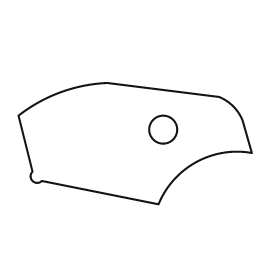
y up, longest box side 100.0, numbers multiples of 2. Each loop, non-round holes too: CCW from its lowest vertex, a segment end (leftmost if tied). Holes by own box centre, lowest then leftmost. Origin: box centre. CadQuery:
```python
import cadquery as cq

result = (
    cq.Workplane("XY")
    .moveTo(10.0, -26.0)
    .threePointArc((26.0, -8.0), (50.0, -4.0))
    .lineTo(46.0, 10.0)
    .threePointArc((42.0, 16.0), (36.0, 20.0))
    .lineTo(-12.0, 26.0)
    .threePointArc((-32.0, 22.0), (-50.0, 12.0))
    .lineTo(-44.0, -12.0)
    .threePointArc((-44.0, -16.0), (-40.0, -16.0))
    .close()
    .moveTo(12.0, 6.0)
    .circle(6.0)
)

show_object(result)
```